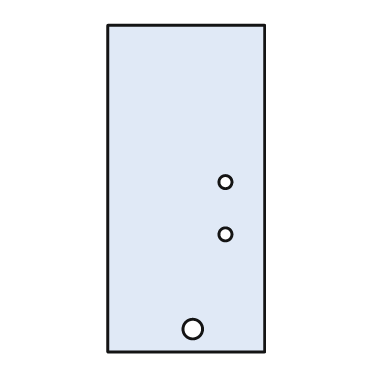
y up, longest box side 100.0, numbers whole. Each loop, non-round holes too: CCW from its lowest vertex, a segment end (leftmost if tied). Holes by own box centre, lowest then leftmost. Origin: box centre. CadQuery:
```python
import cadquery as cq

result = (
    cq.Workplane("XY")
    .moveTo(-24.0, -50.0)
    .lineTo(24.0, -50.0)
    .lineTo(24.0, 50.0)
    .lineTo(-24.0, 50.0)
    .close()
    .moveTo(2.0, -43.0)
    .circle(3.0)
    .moveTo(12.0, -14.0)
    .circle(2.0)
    .moveTo(12.0, 2.0)
    .circle(2.0)
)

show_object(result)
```